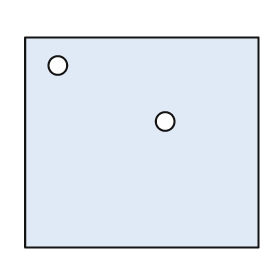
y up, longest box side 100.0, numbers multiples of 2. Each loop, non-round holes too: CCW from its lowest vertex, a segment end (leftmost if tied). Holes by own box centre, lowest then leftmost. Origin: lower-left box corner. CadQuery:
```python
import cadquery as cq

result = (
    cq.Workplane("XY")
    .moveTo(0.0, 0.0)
    .lineTo(100.0, 0.0)
    .lineTo(100.0, 90.0)
    .lineTo(0.0, 90.0)
    .close()
    .moveTo(60.0, 54.0)
    .circle(4.0)
    .moveTo(14.0, 78.0)
    .circle(4.0)
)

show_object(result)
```